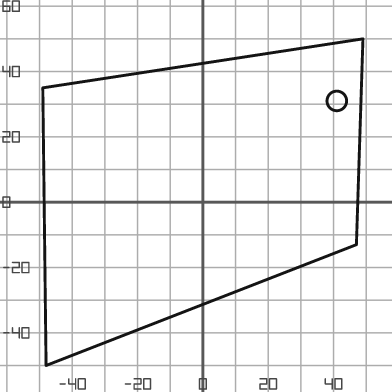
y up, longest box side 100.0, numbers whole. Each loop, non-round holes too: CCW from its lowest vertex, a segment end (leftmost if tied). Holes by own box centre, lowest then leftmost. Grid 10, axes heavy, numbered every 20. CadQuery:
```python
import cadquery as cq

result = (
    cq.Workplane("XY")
    .moveTo(-48.0, -50.0)
    .lineTo(47.0, -13.0)
    .lineTo(49.0, 50.0)
    .lineTo(-49.0, 35.0)
    .close()
    .moveTo(41.0, 31.0)
    .circle(3.0)
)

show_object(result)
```